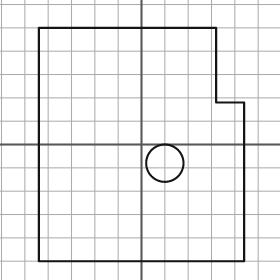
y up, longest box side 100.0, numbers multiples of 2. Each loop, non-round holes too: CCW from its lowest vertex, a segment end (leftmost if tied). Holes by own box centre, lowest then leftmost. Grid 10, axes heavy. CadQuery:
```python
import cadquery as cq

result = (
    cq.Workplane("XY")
    .moveTo(-44.0, -50.0)
    .lineTo(44.0, -50.0)
    .lineTo(44.0, 18.0)
    .lineTo(32.0, 18.0)
    .lineTo(32.0, 50.0)
    .lineTo(-44.0, 50.0)
    .close()
    .moveTo(10.0, -8.0)
    .circle(8.0)
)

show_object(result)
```